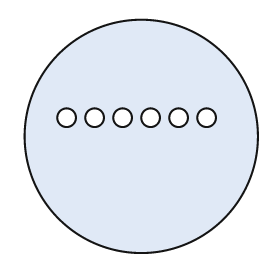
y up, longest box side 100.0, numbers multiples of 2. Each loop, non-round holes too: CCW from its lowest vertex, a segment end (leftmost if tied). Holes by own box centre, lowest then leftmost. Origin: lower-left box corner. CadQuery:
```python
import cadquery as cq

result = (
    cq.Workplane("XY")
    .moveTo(50.0, 50.0)
    .circle(50.0)
    .moveTo(18.0, 58.0)
    .circle(4.0)
    .moveTo(30.0, 58.0)
    .circle(4.0)
    .moveTo(42.0, 58.0)
    .circle(4.0)
    .moveTo(54.0, 58.0)
    .circle(4.0)
    .moveTo(66.0, 58.0)
    .circle(4.0)
    .moveTo(78.0, 58.0)
    .circle(4.0)
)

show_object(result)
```